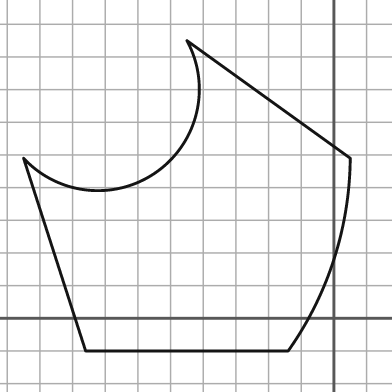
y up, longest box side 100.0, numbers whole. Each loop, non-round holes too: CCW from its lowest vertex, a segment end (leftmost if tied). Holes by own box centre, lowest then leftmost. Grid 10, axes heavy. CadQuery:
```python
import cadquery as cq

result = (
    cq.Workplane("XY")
    .moveTo(-76.0, -10.0)
    .lineTo(-14.0, -10.0)
    .threePointArc((0.0, 18.0), (5.0, 49.0))
    .lineTo(-45.0, 85.0)
    .threePointArc((-54.0, 45.0), (-95.0, 49.0))
    .close()
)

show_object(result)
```